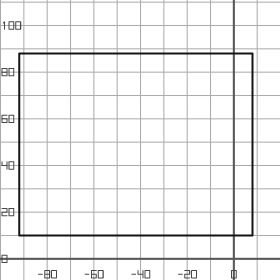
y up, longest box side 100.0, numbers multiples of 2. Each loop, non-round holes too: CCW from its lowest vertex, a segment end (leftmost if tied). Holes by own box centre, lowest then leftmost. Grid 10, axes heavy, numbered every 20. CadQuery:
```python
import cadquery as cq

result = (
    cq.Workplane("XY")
    .moveTo(-92.0, 10.0)
    .lineTo(8.0, 10.0)
    .lineTo(8.0, 88.0)
    .lineTo(-92.0, 88.0)
    .close()
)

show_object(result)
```